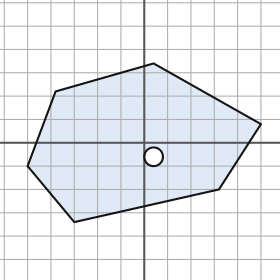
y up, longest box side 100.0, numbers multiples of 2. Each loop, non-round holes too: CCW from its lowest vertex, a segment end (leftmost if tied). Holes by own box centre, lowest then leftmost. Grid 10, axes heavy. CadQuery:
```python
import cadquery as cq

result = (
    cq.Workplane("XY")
    .moveTo(-30.0, -34.0)
    .lineTo(32.0, -20.0)
    .lineTo(50.0, 8.0)
    .lineTo(4.0, 34.0)
    .lineTo(-38.0, 22.0)
    .lineTo(-50.0, -10.0)
    .close()
    .moveTo(4.0, -6.0)
    .circle(4.0)
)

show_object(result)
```